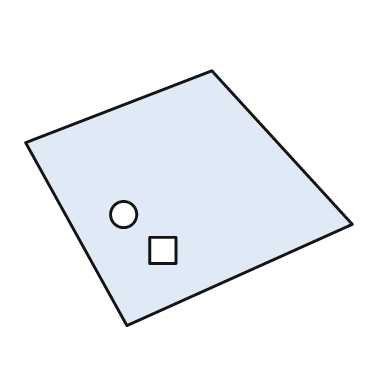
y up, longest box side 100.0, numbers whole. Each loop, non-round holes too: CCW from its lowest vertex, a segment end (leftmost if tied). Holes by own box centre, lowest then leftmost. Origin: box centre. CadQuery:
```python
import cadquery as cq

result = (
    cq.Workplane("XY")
    .moveTo(-19.0, -39.0)
    .lineTo(50.0, -8.0)
    .lineTo(7.0, 39.0)
    .lineTo(-50.0, 17.0)
    .close()
    .moveTo(-12.0, -20.0)
    .lineTo(-4.0, -20.0)
    .lineTo(-4.0, -12.0)
    .lineTo(-12.0, -12.0)
    .close()
    .moveTo(-20.0, -5.0)
    .circle(4.0)
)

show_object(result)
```